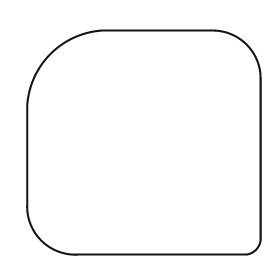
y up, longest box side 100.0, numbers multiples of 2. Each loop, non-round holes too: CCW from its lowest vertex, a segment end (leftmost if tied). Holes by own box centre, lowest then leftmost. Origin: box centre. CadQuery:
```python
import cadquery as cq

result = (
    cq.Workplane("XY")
    .moveTo(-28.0, -48.0)
    .lineTo(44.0, -48.0)
    .threePointArc((48.0, -46.0), (50.0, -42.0))
    .lineTo(50.0, 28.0)
    .threePointArc((44.0, 42.0), (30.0, 48.0))
    .lineTo(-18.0, 48.0)
    .threePointArc((-40.0, 38.0), (-50.0, 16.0))
    .lineTo(-50.0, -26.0)
    .threePointArc((-44.0, -42.0), (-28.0, -48.0))
    .close()
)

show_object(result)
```